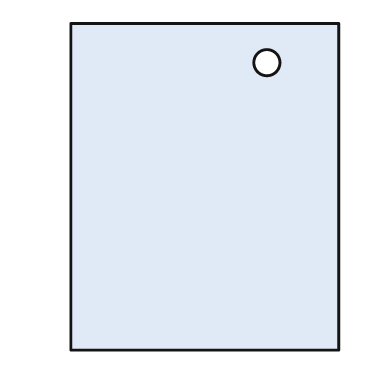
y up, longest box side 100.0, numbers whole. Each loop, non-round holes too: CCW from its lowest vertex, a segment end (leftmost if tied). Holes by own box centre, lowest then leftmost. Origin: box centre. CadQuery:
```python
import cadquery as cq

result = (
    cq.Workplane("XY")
    .moveTo(-41.0, -50.0)
    .lineTo(41.0, -50.0)
    .lineTo(41.0, 50.0)
    .lineTo(-41.0, 50.0)
    .close()
    .moveTo(19.0, 38.0)
    .circle(4.0)
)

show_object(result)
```